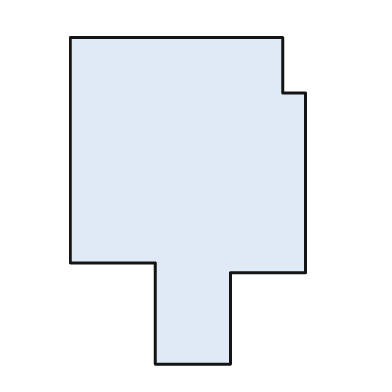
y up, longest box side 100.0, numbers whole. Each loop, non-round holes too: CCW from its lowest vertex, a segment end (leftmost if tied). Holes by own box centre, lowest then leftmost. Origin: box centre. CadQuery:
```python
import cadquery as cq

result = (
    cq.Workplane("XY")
    .moveTo(-10.0, -50.0)
    .lineTo(13.0, -50.0)
    .lineTo(13.0, -22.0)
    .lineTo(36.0, -22.0)
    .lineTo(36.0, 33.0)
    .lineTo(29.0, 33.0)
    .lineTo(29.0, 50.0)
    .lineTo(-36.0, 50.0)
    .lineTo(-36.0, -19.0)
    .lineTo(-10.0, -19.0)
    .close()
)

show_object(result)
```